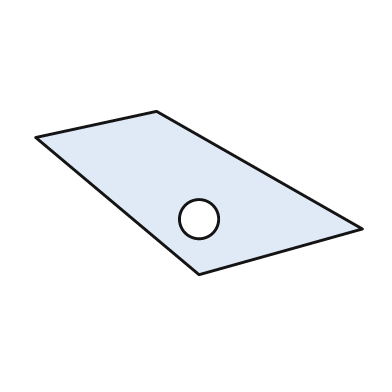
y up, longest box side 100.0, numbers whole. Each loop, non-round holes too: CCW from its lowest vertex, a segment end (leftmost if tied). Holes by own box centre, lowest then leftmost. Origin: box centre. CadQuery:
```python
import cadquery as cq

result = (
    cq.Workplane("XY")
    .moveTo(0.0, -25.0)
    .lineTo(50.0, -11.0)
    .lineTo(-13.0, 25.0)
    .lineTo(-50.0, 17.0)
    .close()
    .moveTo(0.0, -8.0)
    .circle(6.0)
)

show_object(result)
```